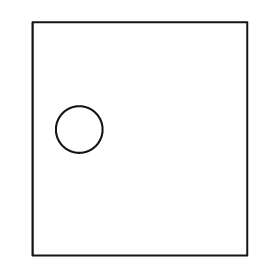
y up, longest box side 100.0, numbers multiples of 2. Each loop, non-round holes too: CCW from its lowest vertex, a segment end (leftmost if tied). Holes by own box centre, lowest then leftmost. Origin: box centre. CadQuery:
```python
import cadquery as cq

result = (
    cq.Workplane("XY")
    .moveTo(-46.0, -50.0)
    .lineTo(46.0, -50.0)
    .lineTo(46.0, 50.0)
    .lineTo(-46.0, 50.0)
    .close()
    .moveTo(-26.0, 4.0)
    .circle(10.0)
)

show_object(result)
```